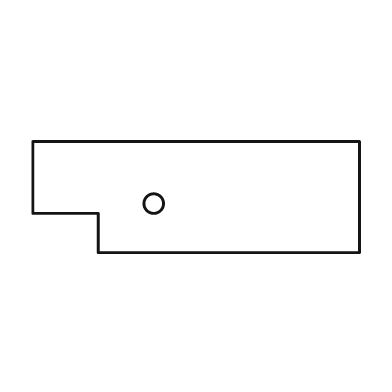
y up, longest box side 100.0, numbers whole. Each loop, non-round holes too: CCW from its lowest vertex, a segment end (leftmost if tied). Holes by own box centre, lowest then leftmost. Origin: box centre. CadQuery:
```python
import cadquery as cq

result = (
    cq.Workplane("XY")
    .moveTo(-30.0, -17.0)
    .lineTo(50.0, -17.0)
    .lineTo(50.0, 17.0)
    .lineTo(-50.0, 17.0)
    .lineTo(-50.0, -5.0)
    .lineTo(-30.0, -5.0)
    .close()
    .moveTo(-13.0, -2.0)
    .circle(3.0)
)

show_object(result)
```